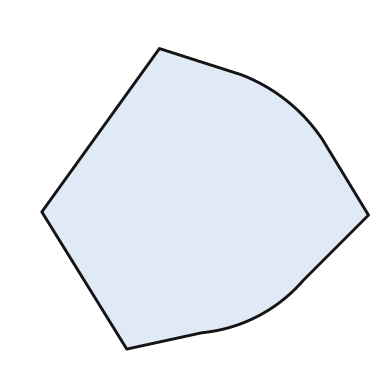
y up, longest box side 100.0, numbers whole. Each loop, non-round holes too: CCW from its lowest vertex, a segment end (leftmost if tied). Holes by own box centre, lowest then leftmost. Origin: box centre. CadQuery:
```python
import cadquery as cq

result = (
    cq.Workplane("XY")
    .moveTo(-24.0, -46.0)
    .lineTo(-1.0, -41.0)
    .threePointArc((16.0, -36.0), (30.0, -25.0))
    .lineTo(50.0, -5.0)
    .lineTo(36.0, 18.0)
    .threePointArc((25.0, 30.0), (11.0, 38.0))
    .lineTo(-14.0, 46.0)
    .lineTo(-50.0, -4.0)
    .close()
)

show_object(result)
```